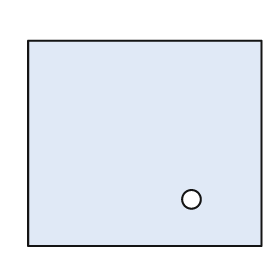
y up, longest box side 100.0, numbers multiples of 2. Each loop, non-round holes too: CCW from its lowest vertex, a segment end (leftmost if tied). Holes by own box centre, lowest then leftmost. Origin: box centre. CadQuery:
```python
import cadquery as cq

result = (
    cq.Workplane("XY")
    .moveTo(-50.0, -44.0)
    .lineTo(50.0, -44.0)
    .lineTo(50.0, 44.0)
    .lineTo(-50.0, 44.0)
    .close()
    .moveTo(20.0, -24.0)
    .circle(4.0)
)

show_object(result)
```